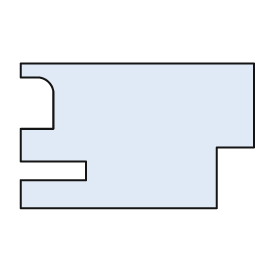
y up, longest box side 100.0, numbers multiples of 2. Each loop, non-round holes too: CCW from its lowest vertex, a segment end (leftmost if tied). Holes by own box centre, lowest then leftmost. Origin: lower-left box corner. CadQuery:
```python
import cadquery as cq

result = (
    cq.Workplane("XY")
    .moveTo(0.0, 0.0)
    .lineTo(84.0, 0.0)
    .lineTo(84.0, 26.0)
    .lineTo(100.0, 26.0)
    .lineTo(100.0, 62.0)
    .lineTo(0.0, 62.0)
    .lineTo(0.0, 56.0)
    .lineTo(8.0, 56.0)
    .threePointArc((12.0, 54.0), (14.0, 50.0))
    .lineTo(14.0, 34.0)
    .lineTo(0.0, 34.0)
    .lineTo(0.0, 20.0)
    .lineTo(28.0, 20.0)
    .lineTo(28.0, 12.0)
    .lineTo(0.0, 12.0)
    .close()
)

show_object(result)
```